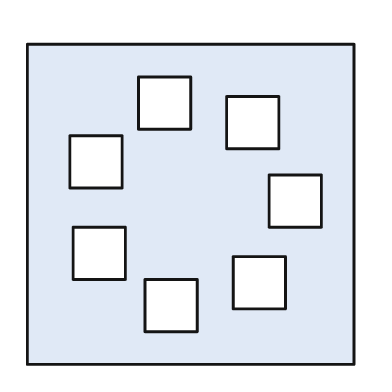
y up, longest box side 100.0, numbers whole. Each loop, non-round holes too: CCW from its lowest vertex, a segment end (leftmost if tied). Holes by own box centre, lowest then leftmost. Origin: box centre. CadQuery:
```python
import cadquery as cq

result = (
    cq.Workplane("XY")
    .moveTo(-50.0, -49.0)
    .lineTo(50.0, -49.0)
    .lineTo(50.0, 49.0)
    .lineTo(-50.0, 49.0)
    .close()
    .moveTo(-14.0, -39.0)
    .lineTo(2.0, -39.0)
    .lineTo(2.0, -23.0)
    .lineTo(-14.0, -23.0)
    .close()
    .moveTo(13.0, -32.0)
    .lineTo(29.0, -32.0)
    .lineTo(29.0, -16.0)
    .lineTo(13.0, -16.0)
    .close()
    .moveTo(-36.0, -23.0)
    .lineTo(-20.0, -23.0)
    .lineTo(-20.0, -7.0)
    .lineTo(-36.0, -7.0)
    .close()
    .moveTo(24.0, -7.0)
    .lineTo(40.0, -7.0)
    .lineTo(40.0, 9.0)
    .lineTo(24.0, 9.0)
    .close()
    .moveTo(-37.0, 5.0)
    .lineTo(-21.0, 5.0)
    .lineTo(-21.0, 21.0)
    .lineTo(-37.0, 21.0)
    .close()
    .moveTo(11.0, 17.0)
    .lineTo(27.0, 17.0)
    .lineTo(27.0, 33.0)
    .lineTo(11.0, 33.0)
    .close()
    .moveTo(-16.0, 23.0)
    .lineTo(0.0, 23.0)
    .lineTo(0.0, 39.0)
    .lineTo(-16.0, 39.0)
    .close()
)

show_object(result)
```